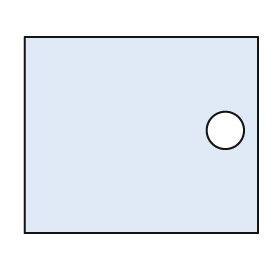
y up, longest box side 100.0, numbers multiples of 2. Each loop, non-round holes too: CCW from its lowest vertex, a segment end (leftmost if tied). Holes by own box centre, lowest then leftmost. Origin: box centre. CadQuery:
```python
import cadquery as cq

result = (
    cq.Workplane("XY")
    .moveTo(-50.0, -42.0)
    .lineTo(50.0, -42.0)
    .lineTo(50.0, 42.0)
    .lineTo(-50.0, 42.0)
    .close()
    .moveTo(36.0, 2.0)
    .circle(8.0)
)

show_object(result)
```